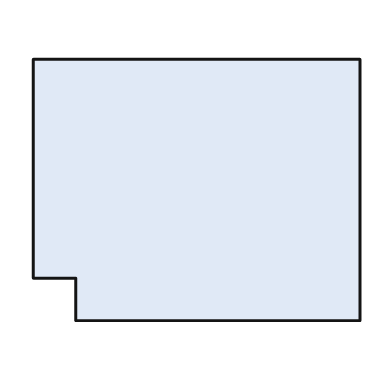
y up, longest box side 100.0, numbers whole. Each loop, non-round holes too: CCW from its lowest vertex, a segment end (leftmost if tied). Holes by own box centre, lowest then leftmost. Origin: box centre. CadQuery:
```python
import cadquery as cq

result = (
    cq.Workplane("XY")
    .moveTo(-37.0, -40.0)
    .lineTo(50.0, -40.0)
    .lineTo(50.0, 40.0)
    .lineTo(-50.0, 40.0)
    .lineTo(-50.0, -27.0)
    .lineTo(-37.0, -27.0)
    .close()
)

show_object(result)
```